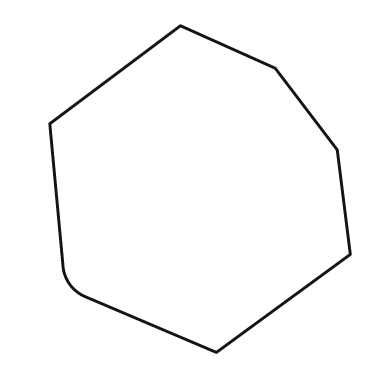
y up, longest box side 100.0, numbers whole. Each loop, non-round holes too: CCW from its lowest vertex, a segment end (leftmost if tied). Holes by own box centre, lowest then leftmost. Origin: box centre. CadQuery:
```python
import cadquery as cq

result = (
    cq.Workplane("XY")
    .moveTo(5.0, -50.0)
    .lineTo(46.0, -20.0)
    .lineTo(42.0, 12.0)
    .lineTo(23.0, 37.0)
    .lineTo(-6.0, 50.0)
    .lineTo(-46.0, 20.0)
    .lineTo(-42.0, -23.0)
    .threePointArc((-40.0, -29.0), (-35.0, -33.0))
    .close()
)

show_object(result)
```